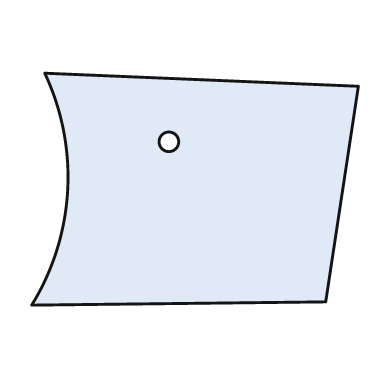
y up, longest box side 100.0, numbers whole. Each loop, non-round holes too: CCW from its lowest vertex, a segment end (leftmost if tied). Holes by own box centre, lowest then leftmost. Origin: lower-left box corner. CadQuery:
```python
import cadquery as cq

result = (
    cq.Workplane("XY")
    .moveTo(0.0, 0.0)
    .lineTo(90.0, 1.0)
    .lineTo(100.0, 67.0)
    .lineTo(4.0, 71.0)
    .threePointArc((11.0, 35.0), (0.0, 0.0))
    .close()
    .moveTo(42.0, 50.0)
    .circle(3.0)
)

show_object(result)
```